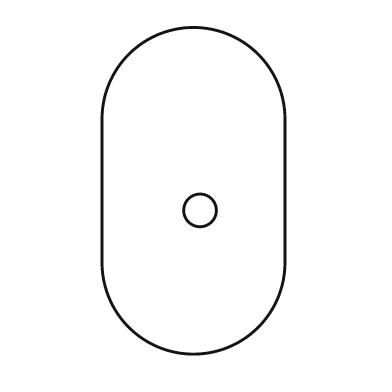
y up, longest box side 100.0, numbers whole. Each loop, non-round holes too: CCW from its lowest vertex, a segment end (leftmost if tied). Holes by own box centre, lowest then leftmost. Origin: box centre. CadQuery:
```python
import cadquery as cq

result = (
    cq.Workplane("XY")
    .moveTo(-28.0, -22.0)
    .threePointArc((0.0, -50.0), (28.0, -22.0))
    .lineTo(28.0, 22.0)
    .threePointArc((0.0, 50.0), (-28.0, 22.0))
    .close()
    .moveTo(2.0, -6.0)
    .circle(5.0)
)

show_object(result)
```